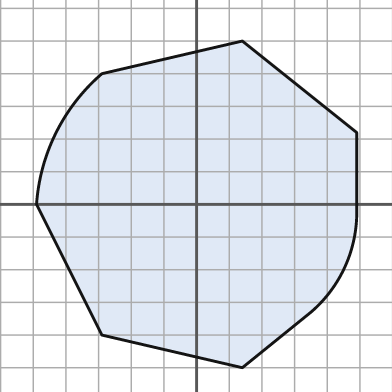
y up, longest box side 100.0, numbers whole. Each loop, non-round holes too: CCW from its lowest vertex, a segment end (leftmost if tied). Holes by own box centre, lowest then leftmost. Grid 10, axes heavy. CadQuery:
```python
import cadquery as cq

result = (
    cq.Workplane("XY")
    .moveTo(14.0, -50.0)
    .lineTo(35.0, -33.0)
    .threePointArc((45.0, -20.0), (49.0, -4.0))
    .lineTo(49.0, 22.0)
    .lineTo(14.0, 50.0)
    .lineTo(-29.0, 40.0)
    .threePointArc((-43.0, 22.0), (-49.0, 0.0))
    .lineTo(-29.0, -40.0)
    .close()
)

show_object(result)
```